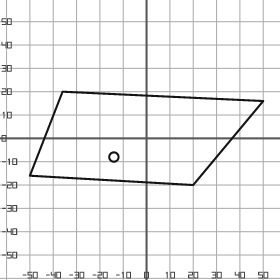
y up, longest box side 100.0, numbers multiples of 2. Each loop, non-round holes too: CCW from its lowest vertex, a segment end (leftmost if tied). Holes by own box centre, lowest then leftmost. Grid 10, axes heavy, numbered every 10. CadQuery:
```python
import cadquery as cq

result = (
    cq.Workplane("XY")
    .moveTo(20.0, -20.0)
    .lineTo(50.0, 16.0)
    .lineTo(-36.0, 20.0)
    .lineTo(-50.0, -16.0)
    .close()
    .moveTo(-14.0, -8.0)
    .circle(2.0)
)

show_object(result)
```